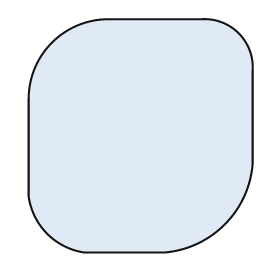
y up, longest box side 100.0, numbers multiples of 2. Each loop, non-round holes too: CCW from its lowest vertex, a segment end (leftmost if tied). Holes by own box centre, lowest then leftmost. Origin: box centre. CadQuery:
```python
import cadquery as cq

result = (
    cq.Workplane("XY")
    .moveTo(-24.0, -50.0)
    .lineTo(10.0, -50.0)
    .threePointArc((36.0, -38.0), (48.0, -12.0))
    .lineTo(48.0, 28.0)
    .threePointArc((42.0, 44.0), (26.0, 50.0))
    .lineTo(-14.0, 50.0)
    .threePointArc((-38.0, 40.0), (-48.0, 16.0))
    .lineTo(-48.0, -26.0)
    .threePointArc((-40.0, -42.0), (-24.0, -50.0))
    .close()
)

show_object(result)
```